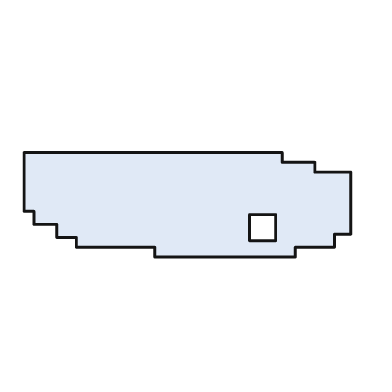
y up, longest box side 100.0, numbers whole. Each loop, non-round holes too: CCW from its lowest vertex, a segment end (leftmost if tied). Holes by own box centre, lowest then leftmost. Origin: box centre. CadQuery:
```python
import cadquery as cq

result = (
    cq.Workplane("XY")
    .moveTo(-10.0, -16.0)
    .lineTo(33.0, -16.0)
    .lineTo(33.0, -13.0)
    .lineTo(45.0, -13.0)
    .lineTo(45.0, -9.0)
    .lineTo(50.0, -9.0)
    .lineTo(50.0, 10.0)
    .lineTo(39.0, 10.0)
    .lineTo(39.0, 13.0)
    .lineTo(29.0, 13.0)
    .lineTo(29.0, 16.0)
    .lineTo(-50.0, 16.0)
    .lineTo(-50.0, -2.0)
    .lineTo(-47.0, -2.0)
    .lineTo(-47.0, -6.0)
    .lineTo(-40.0, -6.0)
    .lineTo(-40.0, -10.0)
    .lineTo(-34.0, -10.0)
    .lineTo(-34.0, -13.0)
    .lineTo(-10.0, -13.0)
    .close()
    .moveTo(19.0, -11.0)
    .lineTo(27.0, -11.0)
    .lineTo(27.0, -3.0)
    .lineTo(19.0, -3.0)
    .close()
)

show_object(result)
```